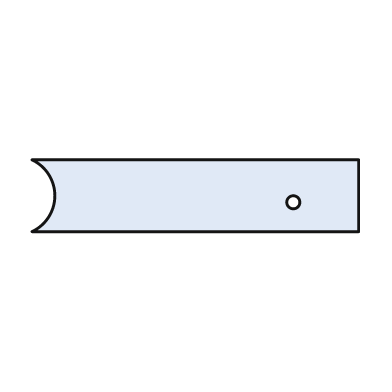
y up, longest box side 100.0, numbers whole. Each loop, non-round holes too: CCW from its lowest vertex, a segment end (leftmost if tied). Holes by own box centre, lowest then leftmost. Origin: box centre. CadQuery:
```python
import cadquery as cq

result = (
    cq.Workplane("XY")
    .moveTo(-50.0, -11.0)
    .lineTo(50.0, -11.0)
    .lineTo(50.0, 11.0)
    .lineTo(-50.0, 11.0)
    .threePointArc((-43.0, 0.0), (-50.0, -11.0))
    .close()
    .moveTo(30.0, -2.0)
    .circle(2.0)
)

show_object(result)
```